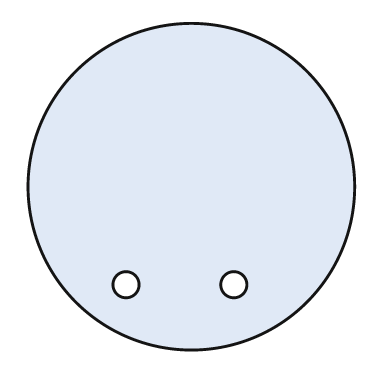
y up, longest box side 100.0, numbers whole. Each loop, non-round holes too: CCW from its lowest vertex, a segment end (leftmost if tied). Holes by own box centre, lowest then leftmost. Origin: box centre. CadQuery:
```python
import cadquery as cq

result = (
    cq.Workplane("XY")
    .moveTo(0.0, 0.0)
    .circle(50.0)
    .moveTo(-20.0, -30.0)
    .circle(4.0)
    .moveTo(13.0, -30.0)
    .circle(4.0)
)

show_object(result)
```